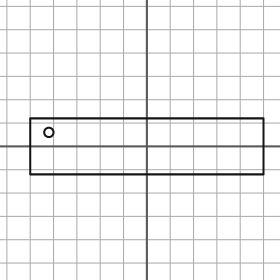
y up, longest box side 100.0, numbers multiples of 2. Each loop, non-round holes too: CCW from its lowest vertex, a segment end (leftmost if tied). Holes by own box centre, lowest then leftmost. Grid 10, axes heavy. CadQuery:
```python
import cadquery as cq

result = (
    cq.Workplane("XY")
    .moveTo(-50.0, -12.0)
    .lineTo(50.0, -12.0)
    .lineTo(50.0, 12.0)
    .lineTo(-50.0, 12.0)
    .close()
    .moveTo(-42.0, 6.0)
    .circle(2.0)
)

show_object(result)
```